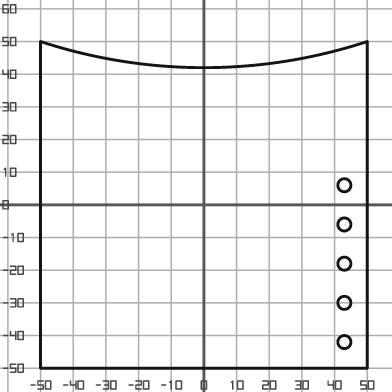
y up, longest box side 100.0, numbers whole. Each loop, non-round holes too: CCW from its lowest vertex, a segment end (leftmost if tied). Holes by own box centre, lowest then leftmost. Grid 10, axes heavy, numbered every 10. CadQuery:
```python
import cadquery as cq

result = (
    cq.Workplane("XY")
    .moveTo(-50.0, -50.0)
    .lineTo(50.0, -50.0)
    .lineTo(50.0, 50.0)
    .threePointArc((0.0, 42.0), (-50.0, 50.0))
    .close()
    .moveTo(43.0, -42.0)
    .circle(2.0)
    .moveTo(43.0, -30.0)
    .circle(2.0)
    .moveTo(43.0, -18.0)
    .circle(2.0)
    .moveTo(43.0, -6.0)
    .circle(2.0)
    .moveTo(43.0, 6.0)
    .circle(2.0)
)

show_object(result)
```